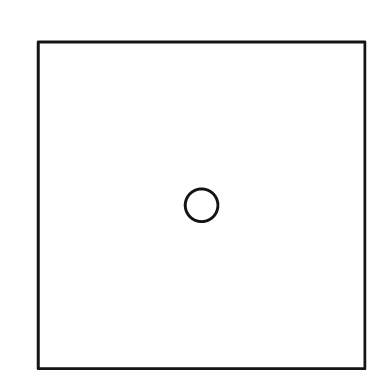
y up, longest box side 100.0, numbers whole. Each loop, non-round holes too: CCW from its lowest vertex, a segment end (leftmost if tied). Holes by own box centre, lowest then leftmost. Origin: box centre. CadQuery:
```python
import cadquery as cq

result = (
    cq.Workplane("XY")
    .moveTo(-50.0, -50.0)
    .lineTo(50.0, -50.0)
    .lineTo(50.0, 50.0)
    .lineTo(-50.0, 50.0)
    .close()
    .moveTo(0.0, 0.0)
    .circle(5.0)
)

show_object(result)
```